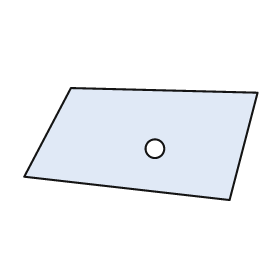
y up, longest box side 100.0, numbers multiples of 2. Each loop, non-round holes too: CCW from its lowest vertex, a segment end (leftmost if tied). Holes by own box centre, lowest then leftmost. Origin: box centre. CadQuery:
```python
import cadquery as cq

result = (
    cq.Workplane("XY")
    .moveTo(38.0, -24.0)
    .lineTo(50.0, 22.0)
    .lineTo(-30.0, 24.0)
    .lineTo(-50.0, -14.0)
    .close()
    .moveTo(6.0, -2.0)
    .circle(4.0)
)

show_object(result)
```